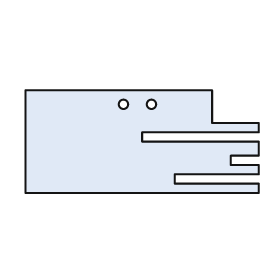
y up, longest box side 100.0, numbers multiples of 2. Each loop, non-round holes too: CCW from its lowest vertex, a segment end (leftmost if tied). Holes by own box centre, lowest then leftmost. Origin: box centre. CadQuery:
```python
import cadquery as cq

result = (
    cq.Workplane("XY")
    .moveTo(-50.0, -22.0)
    .lineTo(50.0, -22.0)
    .lineTo(50.0, -18.0)
    .lineTo(14.0, -18.0)
    .lineTo(14.0, -14.0)
    .lineTo(50.0, -14.0)
    .lineTo(50.0, -10.0)
    .lineTo(38.0, -10.0)
    .lineTo(38.0, -6.0)
    .lineTo(50.0, -6.0)
    .lineTo(50.0, 0.0)
    .lineTo(0.0, 0.0)
    .lineTo(0.0, 4.0)
    .lineTo(50.0, 4.0)
    .lineTo(50.0, 8.0)
    .lineTo(30.0, 8.0)
    .lineTo(30.0, 22.0)
    .lineTo(-50.0, 22.0)
    .close()
    .moveTo(-8.0, 16.0)
    .circle(2.0)
    .moveTo(4.0, 16.0)
    .circle(2.0)
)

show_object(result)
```